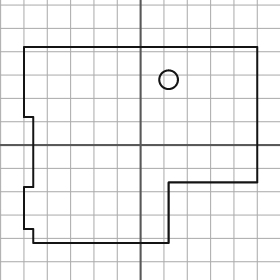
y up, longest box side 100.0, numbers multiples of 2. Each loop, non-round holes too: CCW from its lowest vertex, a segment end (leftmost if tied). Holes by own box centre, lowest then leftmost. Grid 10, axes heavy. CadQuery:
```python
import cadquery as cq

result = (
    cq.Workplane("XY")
    .moveTo(-46.0, -42.0)
    .lineTo(12.0, -42.0)
    .lineTo(12.0, -16.0)
    .lineTo(50.0, -16.0)
    .lineTo(50.0, 42.0)
    .lineTo(-50.0, 42.0)
    .lineTo(-50.0, 12.0)
    .lineTo(-46.0, 12.0)
    .lineTo(-46.0, -18.0)
    .lineTo(-50.0, -18.0)
    .lineTo(-50.0, -36.0)
    .lineTo(-46.0, -36.0)
    .close()
    .moveTo(12.0, 28.0)
    .circle(4.0)
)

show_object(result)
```